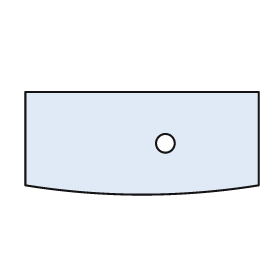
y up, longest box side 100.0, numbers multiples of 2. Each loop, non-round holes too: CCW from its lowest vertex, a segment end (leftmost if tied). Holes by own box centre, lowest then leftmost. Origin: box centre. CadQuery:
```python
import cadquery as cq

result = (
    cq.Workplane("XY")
    .moveTo(-50.0, -18.0)
    .threePointArc((0.0, -22.0), (50.0, -18.0))
    .lineTo(50.0, 22.0)
    .lineTo(-50.0, 22.0)
    .close()
    .moveTo(10.0, 0.0)
    .circle(4.0)
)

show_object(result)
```